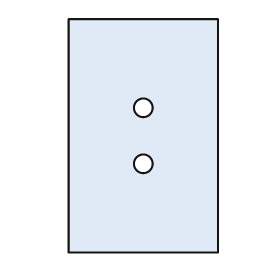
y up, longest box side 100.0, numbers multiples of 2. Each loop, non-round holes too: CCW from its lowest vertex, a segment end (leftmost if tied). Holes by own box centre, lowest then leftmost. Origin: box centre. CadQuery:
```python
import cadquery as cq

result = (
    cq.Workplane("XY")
    .moveTo(-32.0, -50.0)
    .lineTo(32.0, -50.0)
    .lineTo(32.0, 50.0)
    .lineTo(-32.0, 50.0)
    .close()
    .moveTo(0.0, -12.0)
    .circle(4.0)
    .moveTo(0.0, 12.0)
    .circle(4.0)
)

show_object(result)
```